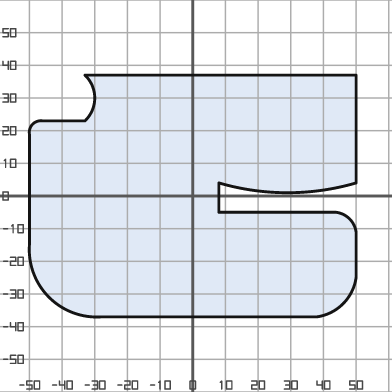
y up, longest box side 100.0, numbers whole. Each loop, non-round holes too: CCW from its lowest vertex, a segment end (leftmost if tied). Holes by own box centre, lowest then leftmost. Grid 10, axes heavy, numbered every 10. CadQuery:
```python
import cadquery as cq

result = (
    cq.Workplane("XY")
    .moveTo(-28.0, -37.0)
    .lineTo(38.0, -37.0)
    .threePointArc((46.0, -33.0), (50.0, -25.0))
    .lineTo(50.0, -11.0)
    .threePointArc((48.0, -7.0), (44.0, -5.0))
    .lineTo(8.0, -5.0)
    .lineTo(8.0, 4.0)
    .threePointArc((29.0, 1.0), (50.0, 4.0))
    .lineTo(50.0, 37.0)
    .lineTo(-33.0, 37.0)
    .threePointArc((-30.0, 30.0), (-33.0, 23.0))
    .lineTo(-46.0, 23.0)
    .threePointArc((-49.0, 22.0), (-50.0, 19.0))
    .lineTo(-50.0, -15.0)
    .threePointArc((-44.0, -31.0), (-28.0, -37.0))
    .close()
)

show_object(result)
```